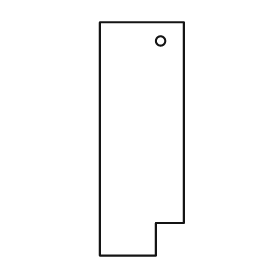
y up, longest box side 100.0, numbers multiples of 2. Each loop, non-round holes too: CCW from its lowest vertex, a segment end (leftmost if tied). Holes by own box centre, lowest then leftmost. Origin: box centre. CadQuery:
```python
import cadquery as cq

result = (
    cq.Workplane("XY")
    .moveTo(-18.0, -50.0)
    .lineTo(6.0, -50.0)
    .lineTo(6.0, -36.0)
    .lineTo(18.0, -36.0)
    .lineTo(18.0, 50.0)
    .lineTo(-18.0, 50.0)
    .close()
    .moveTo(8.0, 42.0)
    .circle(2.0)
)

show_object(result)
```